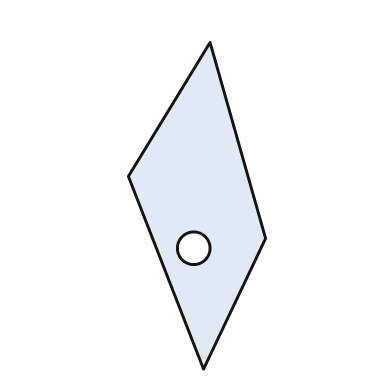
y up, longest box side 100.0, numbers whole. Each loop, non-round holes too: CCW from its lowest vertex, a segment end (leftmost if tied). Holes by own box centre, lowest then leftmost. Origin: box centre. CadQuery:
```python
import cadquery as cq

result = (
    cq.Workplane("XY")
    .moveTo(2.0, -50.0)
    .lineTo(21.0, -10.0)
    .lineTo(4.0, 50.0)
    .lineTo(-21.0, 9.0)
    .close()
    .moveTo(-1.0, -13.0)
    .circle(5.0)
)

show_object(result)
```